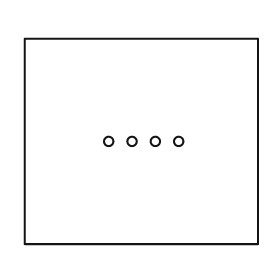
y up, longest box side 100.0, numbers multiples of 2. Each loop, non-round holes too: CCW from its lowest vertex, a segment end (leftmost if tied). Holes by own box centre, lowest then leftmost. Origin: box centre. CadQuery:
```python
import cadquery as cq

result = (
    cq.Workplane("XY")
    .moveTo(-50.0, -44.0)
    .lineTo(50.0, -44.0)
    .lineTo(50.0, 44.0)
    .lineTo(-50.0, 44.0)
    .close()
    .moveTo(-14.0, 0.0)
    .circle(2.0)
    .moveTo(-4.0, 0.0)
    .circle(2.0)
    .moveTo(6.0, 0.0)
    .circle(2.0)
    .moveTo(16.0, 0.0)
    .circle(2.0)
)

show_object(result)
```